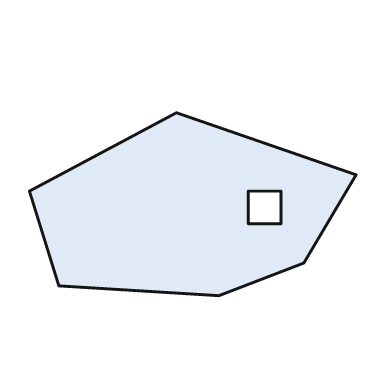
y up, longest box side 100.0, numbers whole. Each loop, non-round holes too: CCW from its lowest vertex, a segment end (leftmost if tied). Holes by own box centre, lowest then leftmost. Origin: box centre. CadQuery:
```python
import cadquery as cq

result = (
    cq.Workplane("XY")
    .moveTo(8.0, -28.0)
    .lineTo(34.0, -18.0)
    .lineTo(50.0, 9.0)
    .lineTo(-5.0, 28.0)
    .lineTo(-50.0, 4.0)
    .lineTo(-41.0, -25.0)
    .close()
    .moveTo(17.0, -6.0)
    .lineTo(27.0, -6.0)
    .lineTo(27.0, 4.0)
    .lineTo(17.0, 4.0)
    .close()
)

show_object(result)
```